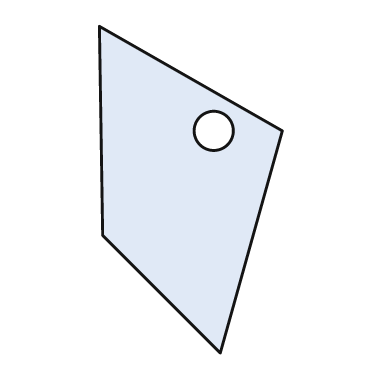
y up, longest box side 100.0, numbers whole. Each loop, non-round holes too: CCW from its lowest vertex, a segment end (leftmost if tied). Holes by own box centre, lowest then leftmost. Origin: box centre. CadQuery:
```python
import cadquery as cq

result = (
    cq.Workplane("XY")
    .moveTo(9.0, -50.0)
    .lineTo(28.0, 18.0)
    .lineTo(-28.0, 50.0)
    .lineTo(-27.0, -14.0)
    .close()
    .moveTo(7.0, 18.0)
    .circle(6.0)
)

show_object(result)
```